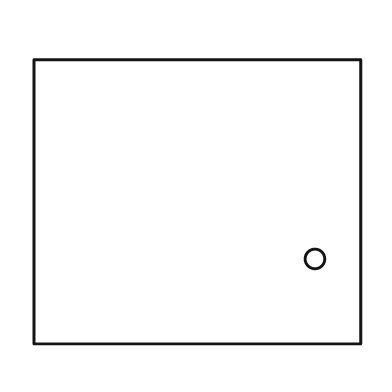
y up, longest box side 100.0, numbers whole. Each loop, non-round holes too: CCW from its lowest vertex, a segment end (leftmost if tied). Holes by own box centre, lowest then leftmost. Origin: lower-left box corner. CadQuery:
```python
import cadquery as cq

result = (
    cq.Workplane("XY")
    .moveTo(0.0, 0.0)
    .lineTo(100.0, 0.0)
    .lineTo(100.0, 87.0)
    .lineTo(0.0, 87.0)
    .close()
    .moveTo(86.0, 26.0)
    .circle(3.0)
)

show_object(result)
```